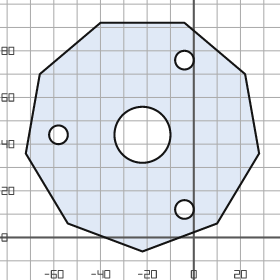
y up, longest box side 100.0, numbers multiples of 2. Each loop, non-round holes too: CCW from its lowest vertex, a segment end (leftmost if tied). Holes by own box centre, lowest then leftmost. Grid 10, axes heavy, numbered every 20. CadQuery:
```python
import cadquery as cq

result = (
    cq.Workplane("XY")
    .moveTo(-22.0, -6.0)
    .lineTo(10.0, 6.0)
    .lineTo(28.0, 36.0)
    .lineTo(22.0, 70.0)
    .lineTo(-4.0, 92.0)
    .lineTo(-40.0, 92.0)
    .lineTo(-66.0, 70.0)
    .lineTo(-72.0, 36.0)
    .lineTo(-54.0, 6.0)
    .close()
    .moveTo(-4.0, 12.0)
    .circle(4.0)
    .moveTo(-58.0, 44.0)
    .circle(4.0)
    .moveTo(-22.0, 44.0)
    .circle(12.0)
    .moveTo(-4.0, 76.0)
    .circle(4.0)
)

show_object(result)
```